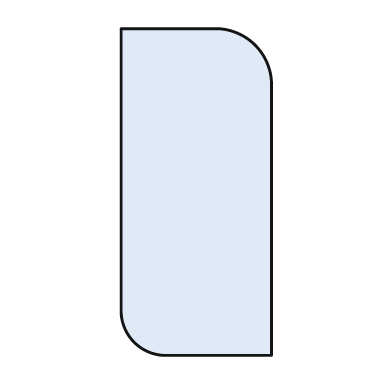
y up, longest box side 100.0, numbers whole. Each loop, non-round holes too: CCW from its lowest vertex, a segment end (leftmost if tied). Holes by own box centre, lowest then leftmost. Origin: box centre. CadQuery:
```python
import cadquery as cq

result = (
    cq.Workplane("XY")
    .moveTo(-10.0, -50.0)
    .lineTo(23.0, -50.0)
    .lineTo(23.0, 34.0)
    .threePointArc((18.0, 45.0), (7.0, 50.0))
    .lineTo(-23.0, 50.0)
    .lineTo(-23.0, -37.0)
    .threePointArc((-19.0, -46.0), (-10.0, -50.0))
    .close()
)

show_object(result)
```